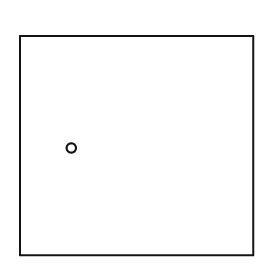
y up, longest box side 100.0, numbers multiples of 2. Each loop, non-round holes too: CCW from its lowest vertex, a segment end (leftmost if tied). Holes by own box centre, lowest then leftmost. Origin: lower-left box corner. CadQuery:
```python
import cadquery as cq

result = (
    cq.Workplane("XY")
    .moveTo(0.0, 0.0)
    .lineTo(100.0, 0.0)
    .lineTo(100.0, 94.0)
    .lineTo(0.0, 94.0)
    .close()
    .moveTo(22.0, 46.0)
    .circle(2.0)
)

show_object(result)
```